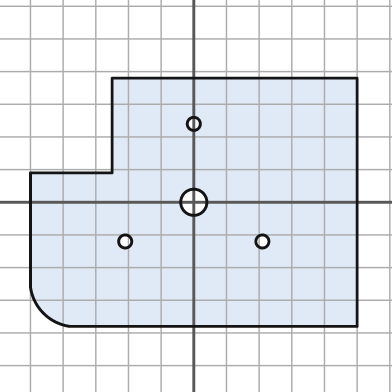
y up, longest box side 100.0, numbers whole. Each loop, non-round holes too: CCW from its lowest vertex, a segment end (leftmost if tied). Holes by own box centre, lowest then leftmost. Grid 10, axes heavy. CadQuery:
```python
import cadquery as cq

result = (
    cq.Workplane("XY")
    .moveTo(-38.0, -38.0)
    .lineTo(50.0, -38.0)
    .lineTo(50.0, 38.0)
    .lineTo(-25.0, 38.0)
    .lineTo(-25.0, 9.0)
    .lineTo(-50.0, 9.0)
    .lineTo(-50.0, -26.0)
    .threePointArc((-46.0, -34.0), (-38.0, -38.0))
    .close()
    .moveTo(-21.0, -12.0)
    .circle(2.0)
    .moveTo(21.0, -12.0)
    .circle(2.0)
    .moveTo(0.0, 0.0)
    .circle(4.0)
    .moveTo(0.0, 24.0)
    .circle(2.0)
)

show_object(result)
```